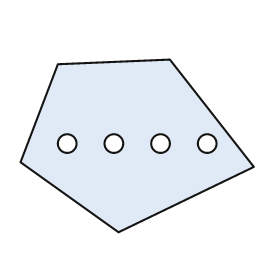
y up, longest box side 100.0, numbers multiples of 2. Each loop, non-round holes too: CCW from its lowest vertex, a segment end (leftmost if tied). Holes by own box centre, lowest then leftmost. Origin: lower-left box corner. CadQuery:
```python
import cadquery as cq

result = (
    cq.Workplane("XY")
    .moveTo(42.0, 0.0)
    .lineTo(100.0, 28.0)
    .lineTo(64.0, 74.0)
    .lineTo(16.0, 72.0)
    .lineTo(0.0, 30.0)
    .close()
    .moveTo(20.0, 38.0)
    .circle(4.0)
    .moveTo(40.0, 38.0)
    .circle(4.0)
    .moveTo(60.0, 38.0)
    .circle(4.0)
    .moveTo(80.0, 38.0)
    .circle(4.0)
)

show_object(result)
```